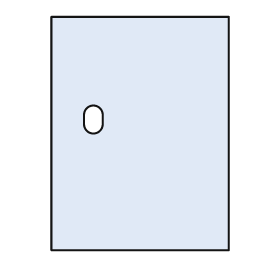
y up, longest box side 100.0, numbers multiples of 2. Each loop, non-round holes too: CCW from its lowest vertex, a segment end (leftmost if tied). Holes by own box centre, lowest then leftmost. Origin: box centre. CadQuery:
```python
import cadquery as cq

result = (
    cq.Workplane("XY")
    .moveTo(-38.0, -50.0)
    .lineTo(38.0, -50.0)
    .lineTo(38.0, 50.0)
    .lineTo(-38.0, 50.0)
    .close()
    .moveTo(-24.0, 4.0)
    .threePointArc((-20.0, 0.0), (-16.0, 4.0))
    .lineTo(-16.0, 8.0)
    .threePointArc((-20.0, 12.0), (-24.0, 8.0))
    .close()
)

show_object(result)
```